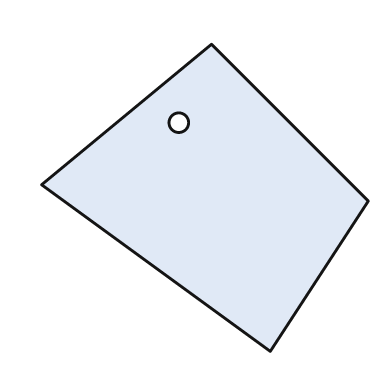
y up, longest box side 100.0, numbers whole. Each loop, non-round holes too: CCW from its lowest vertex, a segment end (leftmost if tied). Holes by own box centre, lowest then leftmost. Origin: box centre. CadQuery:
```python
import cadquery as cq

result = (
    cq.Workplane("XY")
    .moveTo(20.0, -47.0)
    .lineTo(50.0, -1.0)
    .lineTo(2.0, 47.0)
    .lineTo(-50.0, 4.0)
    .close()
    .moveTo(-8.0, 23.0)
    .circle(3.0)
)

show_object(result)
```